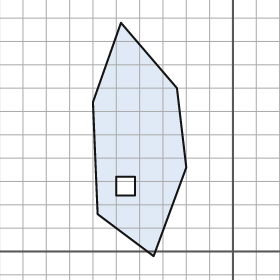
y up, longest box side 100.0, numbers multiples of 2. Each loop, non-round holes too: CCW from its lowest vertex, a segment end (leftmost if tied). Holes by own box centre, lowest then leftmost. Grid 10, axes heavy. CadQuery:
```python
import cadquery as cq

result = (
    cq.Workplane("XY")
    .moveTo(-34.0, -2.0)
    .lineTo(-20.0, 36.0)
    .lineTo(-24.0, 70.0)
    .lineTo(-48.0, 98.0)
    .lineTo(-60.0, 64.0)
    .lineTo(-58.0, 16.0)
    .close()
    .moveTo(-50.0, 24.0)
    .lineTo(-42.0, 24.0)
    .lineTo(-42.0, 32.0)
    .lineTo(-50.0, 32.0)
    .close()
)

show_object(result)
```